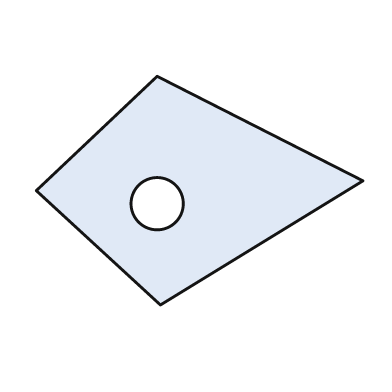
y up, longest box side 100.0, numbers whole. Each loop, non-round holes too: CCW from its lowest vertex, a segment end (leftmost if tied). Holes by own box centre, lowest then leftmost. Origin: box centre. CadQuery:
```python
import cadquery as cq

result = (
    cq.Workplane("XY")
    .moveTo(-12.0, -35.0)
    .lineTo(50.0, 3.0)
    .lineTo(-13.0, 35.0)
    .lineTo(-50.0, 0.0)
    .close()
    .moveTo(-13.0, -4.0)
    .circle(8.0)
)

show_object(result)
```